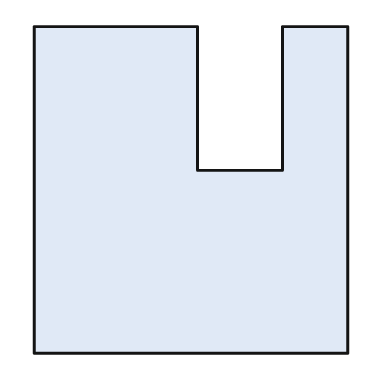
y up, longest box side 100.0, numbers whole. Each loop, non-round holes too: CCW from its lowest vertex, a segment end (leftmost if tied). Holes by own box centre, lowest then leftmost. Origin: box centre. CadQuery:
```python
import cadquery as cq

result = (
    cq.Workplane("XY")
    .moveTo(-48.0, -50.0)
    .lineTo(48.0, -50.0)
    .lineTo(48.0, 50.0)
    .lineTo(28.0, 50.0)
    .lineTo(28.0, 6.0)
    .lineTo(2.0, 6.0)
    .lineTo(2.0, 50.0)
    .lineTo(-48.0, 50.0)
    .close()
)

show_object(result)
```